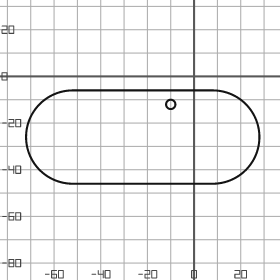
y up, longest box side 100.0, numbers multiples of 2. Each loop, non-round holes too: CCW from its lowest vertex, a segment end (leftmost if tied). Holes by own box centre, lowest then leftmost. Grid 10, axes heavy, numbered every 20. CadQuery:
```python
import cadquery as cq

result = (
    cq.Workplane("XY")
    .moveTo(-52.0, -46.0)
    .lineTo(8.0, -46.0)
    .threePointArc((28.0, -26.0), (8.0, -6.0))
    .lineTo(-52.0, -6.0)
    .threePointArc((-72.0, -26.0), (-52.0, -46.0))
    .close()
    .moveTo(-10.0, -12.0)
    .circle(2.0)
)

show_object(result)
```